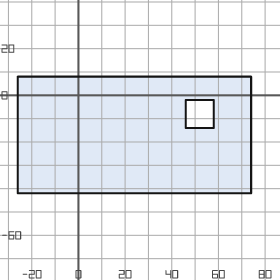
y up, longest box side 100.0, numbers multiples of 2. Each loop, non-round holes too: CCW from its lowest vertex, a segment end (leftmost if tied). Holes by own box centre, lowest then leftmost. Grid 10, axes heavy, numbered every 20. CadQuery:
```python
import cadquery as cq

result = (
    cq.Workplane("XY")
    .moveTo(-26.0, -42.0)
    .lineTo(74.0, -42.0)
    .lineTo(74.0, 8.0)
    .lineTo(-26.0, 8.0)
    .close()
    .moveTo(46.0, -14.0)
    .lineTo(58.0, -14.0)
    .lineTo(58.0, -2.0)
    .lineTo(46.0, -2.0)
    .close()
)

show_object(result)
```